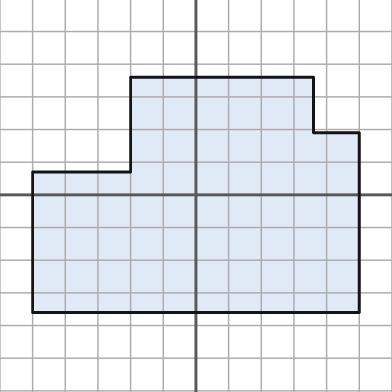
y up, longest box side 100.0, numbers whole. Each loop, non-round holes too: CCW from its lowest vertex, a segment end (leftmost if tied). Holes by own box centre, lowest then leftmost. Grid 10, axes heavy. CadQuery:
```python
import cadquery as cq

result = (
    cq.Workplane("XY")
    .moveTo(-50.0, -36.0)
    .lineTo(50.0, -36.0)
    .lineTo(50.0, 19.0)
    .lineTo(36.0, 19.0)
    .lineTo(36.0, 36.0)
    .lineTo(-20.0, 36.0)
    .lineTo(-20.0, 7.0)
    .lineTo(-50.0, 7.0)
    .close()
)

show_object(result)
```